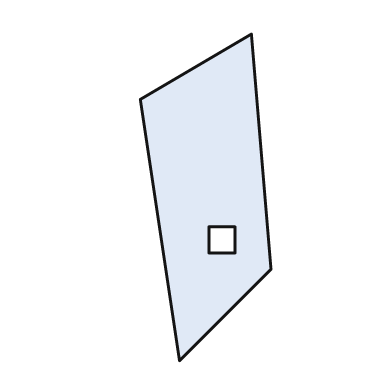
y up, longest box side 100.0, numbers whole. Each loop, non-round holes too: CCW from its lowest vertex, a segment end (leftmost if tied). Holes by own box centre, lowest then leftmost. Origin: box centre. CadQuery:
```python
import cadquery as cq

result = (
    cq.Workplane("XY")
    .moveTo(-8.0, -50.0)
    .lineTo(20.0, -22.0)
    .lineTo(14.0, 50.0)
    .lineTo(-20.0, 30.0)
    .close()
    .moveTo(1.0, -17.0)
    .lineTo(9.0, -17.0)
    .lineTo(9.0, -9.0)
    .lineTo(1.0, -9.0)
    .close()
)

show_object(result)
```